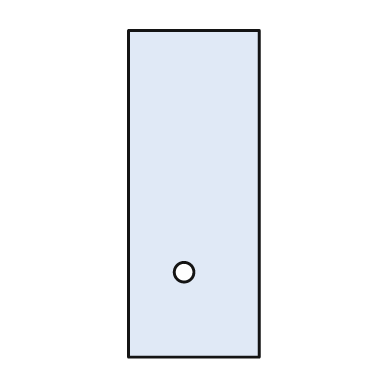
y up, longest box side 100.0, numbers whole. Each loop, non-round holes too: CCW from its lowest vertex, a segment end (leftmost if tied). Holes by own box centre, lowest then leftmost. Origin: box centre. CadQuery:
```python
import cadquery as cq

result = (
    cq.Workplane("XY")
    .moveTo(-20.0, -50.0)
    .lineTo(20.0, -50.0)
    .lineTo(20.0, 50.0)
    .lineTo(-20.0, 50.0)
    .close()
    .moveTo(-3.0, -24.0)
    .circle(3.0)
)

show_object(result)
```